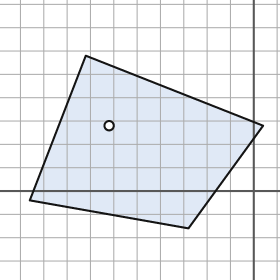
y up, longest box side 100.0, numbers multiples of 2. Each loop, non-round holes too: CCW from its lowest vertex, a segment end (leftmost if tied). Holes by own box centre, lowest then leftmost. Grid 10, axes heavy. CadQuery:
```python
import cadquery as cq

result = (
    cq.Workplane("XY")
    .moveTo(-28.0, -16.0)
    .lineTo(4.0, 28.0)
    .lineTo(-72.0, 58.0)
    .lineTo(-96.0, -4.0)
    .close()
    .moveTo(-62.0, 28.0)
    .circle(2.0)
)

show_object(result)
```